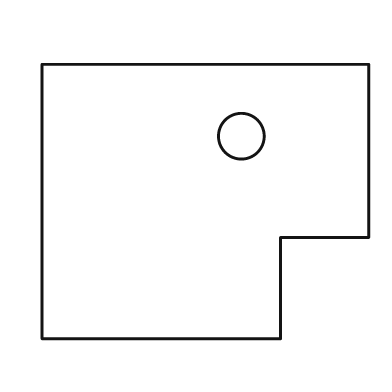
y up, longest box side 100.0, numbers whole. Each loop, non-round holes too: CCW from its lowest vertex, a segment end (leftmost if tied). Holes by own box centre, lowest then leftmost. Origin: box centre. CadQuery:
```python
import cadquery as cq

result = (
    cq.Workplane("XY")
    .moveTo(-50.0, -42.0)
    .lineTo(23.0, -42.0)
    .lineTo(23.0, -11.0)
    .lineTo(50.0, -11.0)
    .lineTo(50.0, 42.0)
    .lineTo(-50.0, 42.0)
    .close()
    .moveTo(11.0, 20.0)
    .circle(7.0)
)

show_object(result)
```